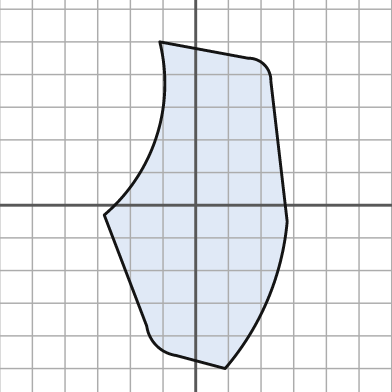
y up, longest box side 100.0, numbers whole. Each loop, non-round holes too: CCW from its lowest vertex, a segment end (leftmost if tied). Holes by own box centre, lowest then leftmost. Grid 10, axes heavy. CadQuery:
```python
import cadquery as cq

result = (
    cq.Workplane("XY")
    .moveTo(9.0, -50.0)
    .threePointArc((22.0, -29.0), (28.0, -5.0))
    .lineTo(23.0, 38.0)
    .threePointArc((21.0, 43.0), (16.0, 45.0))
    .lineTo(-11.0, 50.0)
    .threePointArc((-12.0, 21.0), (-28.0, -3.0))
    .lineTo(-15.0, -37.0)
    .threePointArc((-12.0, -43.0), (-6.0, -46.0))
    .close()
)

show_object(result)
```